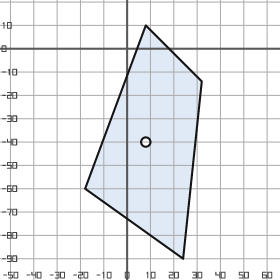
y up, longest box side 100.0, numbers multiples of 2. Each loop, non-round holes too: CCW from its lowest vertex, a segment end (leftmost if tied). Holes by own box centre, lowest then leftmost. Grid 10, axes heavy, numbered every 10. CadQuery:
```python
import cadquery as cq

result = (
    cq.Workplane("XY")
    .moveTo(24.0, -90.0)
    .lineTo(32.0, -14.0)
    .lineTo(8.0, 10.0)
    .lineTo(-18.0, -60.0)
    .close()
    .moveTo(8.0, -40.0)
    .circle(2.0)
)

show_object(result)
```